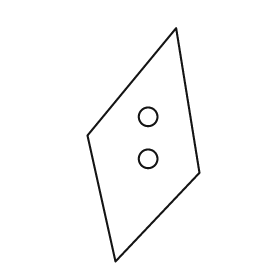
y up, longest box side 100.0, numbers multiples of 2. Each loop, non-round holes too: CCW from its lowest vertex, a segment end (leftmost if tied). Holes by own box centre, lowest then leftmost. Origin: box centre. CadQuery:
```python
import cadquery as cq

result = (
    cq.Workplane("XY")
    .moveTo(-12.0, -50.0)
    .lineTo(24.0, -12.0)
    .lineTo(14.0, 50.0)
    .lineTo(-24.0, 4.0)
    .close()
    .moveTo(2.0, -6.0)
    .circle(4.0)
    .moveTo(2.0, 12.0)
    .circle(4.0)
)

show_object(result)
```